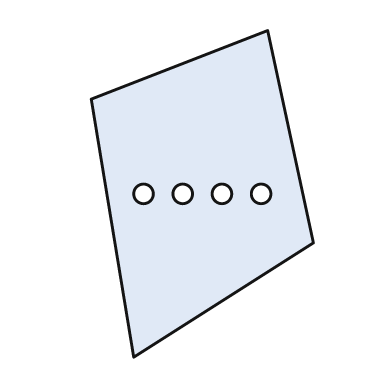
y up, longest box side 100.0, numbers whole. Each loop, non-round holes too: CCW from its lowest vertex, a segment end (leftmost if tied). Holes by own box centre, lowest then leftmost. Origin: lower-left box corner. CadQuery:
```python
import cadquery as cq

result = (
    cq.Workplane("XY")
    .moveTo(13.0, 0.0)
    .lineTo(68.0, 35.0)
    .lineTo(54.0, 100.0)
    .lineTo(0.0, 79.0)
    .close()
    .moveTo(16.0, 50.0)
    .circle(3.0)
    .moveTo(28.0, 50.0)
    .circle(3.0)
    .moveTo(40.0, 50.0)
    .circle(3.0)
    .moveTo(52.0, 50.0)
    .circle(3.0)
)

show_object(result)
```